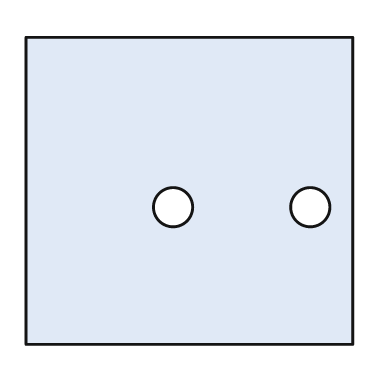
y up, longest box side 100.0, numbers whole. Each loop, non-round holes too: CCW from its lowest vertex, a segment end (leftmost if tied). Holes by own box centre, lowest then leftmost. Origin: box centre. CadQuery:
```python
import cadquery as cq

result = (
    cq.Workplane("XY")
    .moveTo(-50.0, -47.0)
    .lineTo(50.0, -47.0)
    .lineTo(50.0, 47.0)
    .lineTo(-50.0, 47.0)
    .close()
    .moveTo(-5.0, -5.0)
    .circle(6.0)
    .moveTo(37.0, -5.0)
    .circle(6.0)
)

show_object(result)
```